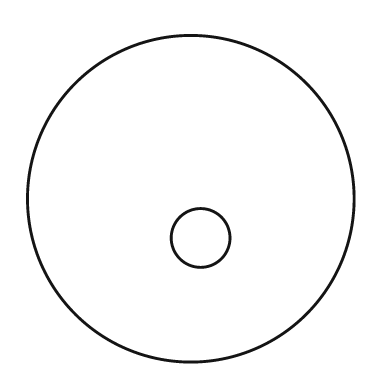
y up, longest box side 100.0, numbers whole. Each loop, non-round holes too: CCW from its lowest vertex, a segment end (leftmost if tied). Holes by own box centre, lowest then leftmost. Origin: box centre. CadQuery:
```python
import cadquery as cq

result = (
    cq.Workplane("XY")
    .moveTo(0.0, 0.0)
    .circle(50.0)
    .moveTo(3.0, -12.0)
    .circle(9.0)
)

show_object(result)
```